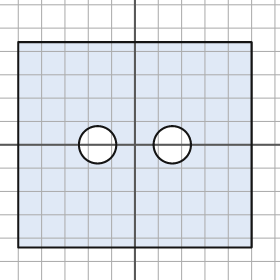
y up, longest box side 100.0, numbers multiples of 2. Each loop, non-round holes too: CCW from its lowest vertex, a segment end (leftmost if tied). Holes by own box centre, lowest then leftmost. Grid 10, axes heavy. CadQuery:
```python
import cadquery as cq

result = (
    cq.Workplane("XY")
    .moveTo(-50.0, -44.0)
    .lineTo(50.0, -44.0)
    .lineTo(50.0, 44.0)
    .lineTo(-50.0, 44.0)
    .close()
    .moveTo(-16.0, 0.0)
    .circle(8.0)
    .moveTo(16.0, 0.0)
    .circle(8.0)
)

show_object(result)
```